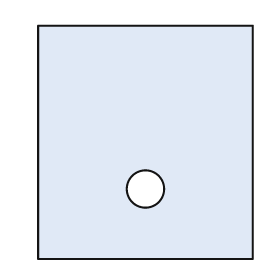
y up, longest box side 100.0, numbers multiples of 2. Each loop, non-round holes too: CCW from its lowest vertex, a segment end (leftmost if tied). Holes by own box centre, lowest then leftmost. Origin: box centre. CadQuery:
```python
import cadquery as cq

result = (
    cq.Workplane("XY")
    .moveTo(-46.0, -50.0)
    .lineTo(46.0, -50.0)
    .lineTo(46.0, 50.0)
    .lineTo(-46.0, 50.0)
    .close()
    .moveTo(0.0, -20.0)
    .circle(8.0)
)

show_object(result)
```